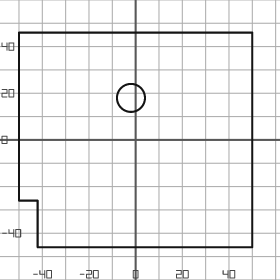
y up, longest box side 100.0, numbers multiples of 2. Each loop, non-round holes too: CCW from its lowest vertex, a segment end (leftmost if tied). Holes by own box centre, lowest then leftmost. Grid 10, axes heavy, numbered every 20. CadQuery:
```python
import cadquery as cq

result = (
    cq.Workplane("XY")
    .moveTo(-42.0, -46.0)
    .lineTo(50.0, -46.0)
    .lineTo(50.0, 46.0)
    .lineTo(-50.0, 46.0)
    .lineTo(-50.0, -26.0)
    .lineTo(-42.0, -26.0)
    .close()
    .moveTo(-2.0, 18.0)
    .circle(6.0)
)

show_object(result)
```